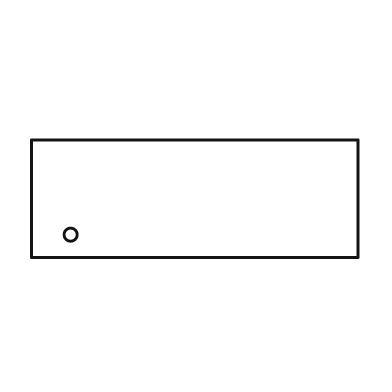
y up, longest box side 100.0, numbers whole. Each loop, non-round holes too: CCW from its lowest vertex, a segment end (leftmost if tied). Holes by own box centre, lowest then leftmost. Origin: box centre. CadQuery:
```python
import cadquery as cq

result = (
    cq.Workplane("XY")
    .moveTo(-50.0, -18.0)
    .lineTo(50.0, -18.0)
    .lineTo(50.0, 18.0)
    .lineTo(-50.0, 18.0)
    .close()
    .moveTo(-38.0, -11.0)
    .circle(2.0)
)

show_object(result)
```